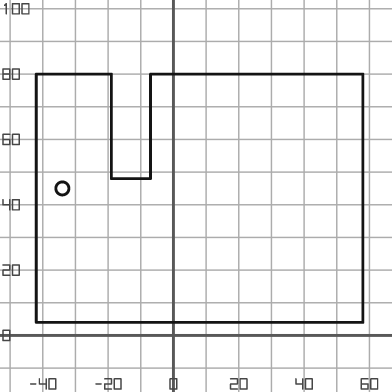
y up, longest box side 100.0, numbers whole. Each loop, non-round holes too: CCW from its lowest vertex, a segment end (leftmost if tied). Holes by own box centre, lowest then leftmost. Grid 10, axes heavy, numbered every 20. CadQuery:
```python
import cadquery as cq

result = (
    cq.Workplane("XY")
    .moveTo(-42.0, 4.0)
    .lineTo(58.0, 4.0)
    .lineTo(58.0, 80.0)
    .lineTo(-7.0, 80.0)
    .lineTo(-7.0, 48.0)
    .lineTo(-19.0, 48.0)
    .lineTo(-19.0, 80.0)
    .lineTo(-42.0, 80.0)
    .close()
    .moveTo(-34.0, 45.0)
    .circle(2.0)
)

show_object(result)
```